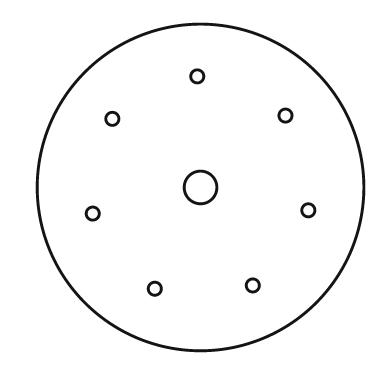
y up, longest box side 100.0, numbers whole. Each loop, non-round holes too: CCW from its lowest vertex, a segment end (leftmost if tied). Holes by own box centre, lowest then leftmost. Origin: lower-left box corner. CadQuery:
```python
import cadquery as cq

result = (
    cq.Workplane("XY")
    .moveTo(50.0, 50.0)
    .circle(50.0)
    .moveTo(36.0, 19.0)
    .circle(2.0)
    .moveTo(66.0, 20.0)
    .circle(2.0)
    .moveTo(17.0, 42.0)
    .circle(2.0)
    .moveTo(83.0, 43.0)
    .circle(2.0)
    .moveTo(50.0, 50.0)
    .circle(5.0)
    .moveTo(23.0, 71.0)
    .circle(2.0)
    .moveTo(76.0, 72.0)
    .circle(2.0)
    .moveTo(49.0, 84.0)
    .circle(2.0)
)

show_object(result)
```